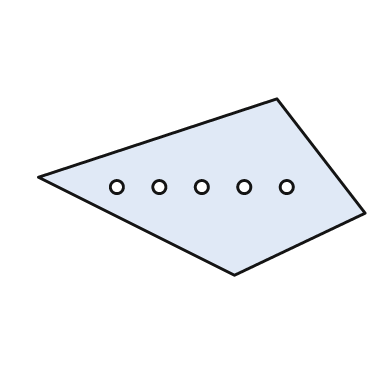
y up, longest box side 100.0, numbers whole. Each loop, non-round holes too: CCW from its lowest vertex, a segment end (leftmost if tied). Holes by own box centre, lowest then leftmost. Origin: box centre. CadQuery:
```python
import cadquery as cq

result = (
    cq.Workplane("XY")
    .moveTo(10.0, -27.0)
    .lineTo(50.0, -8.0)
    .lineTo(23.0, 27.0)
    .lineTo(-50.0, 3.0)
    .close()
    .moveTo(-26.0, 0.0)
    .circle(2.0)
    .moveTo(-13.0, 0.0)
    .circle(2.0)
    .moveTo(0.0, 0.0)
    .circle(2.0)
    .moveTo(13.0, 0.0)
    .circle(2.0)
    .moveTo(26.0, 0.0)
    .circle(2.0)
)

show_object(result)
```